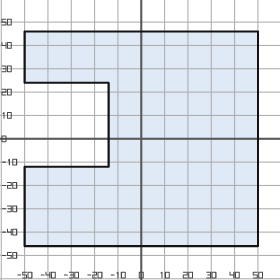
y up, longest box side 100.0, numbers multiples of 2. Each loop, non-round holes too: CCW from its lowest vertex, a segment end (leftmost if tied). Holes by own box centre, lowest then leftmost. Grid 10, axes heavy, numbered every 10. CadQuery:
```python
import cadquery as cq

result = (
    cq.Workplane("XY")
    .moveTo(-50.0, -46.0)
    .lineTo(50.0, -46.0)
    .lineTo(50.0, 46.0)
    .lineTo(-50.0, 46.0)
    .lineTo(-50.0, 24.0)
    .lineTo(-14.0, 24.0)
    .lineTo(-14.0, -12.0)
    .lineTo(-50.0, -12.0)
    .close()
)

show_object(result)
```